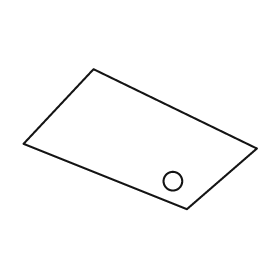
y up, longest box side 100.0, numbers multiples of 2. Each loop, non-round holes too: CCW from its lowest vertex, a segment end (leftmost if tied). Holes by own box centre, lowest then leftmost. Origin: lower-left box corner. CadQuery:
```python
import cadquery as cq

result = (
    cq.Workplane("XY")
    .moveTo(70.0, 0.0)
    .lineTo(100.0, 26.0)
    .lineTo(30.0, 60.0)
    .lineTo(0.0, 28.0)
    .close()
    .moveTo(64.0, 12.0)
    .circle(4.0)
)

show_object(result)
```